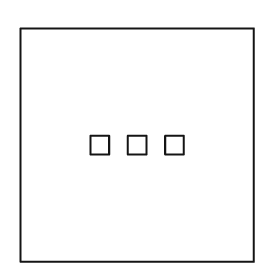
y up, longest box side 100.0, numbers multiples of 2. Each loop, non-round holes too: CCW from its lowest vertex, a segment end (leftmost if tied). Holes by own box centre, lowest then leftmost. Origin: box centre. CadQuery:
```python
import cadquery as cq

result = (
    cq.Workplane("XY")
    .moveTo(-50.0, -50.0)
    .lineTo(50.0, -50.0)
    .lineTo(50.0, 50.0)
    .lineTo(-50.0, 50.0)
    .close()
    .moveTo(-20.0, -4.0)
    .lineTo(-12.0, -4.0)
    .lineTo(-12.0, 4.0)
    .lineTo(-20.0, 4.0)
    .close()
    .moveTo(-4.0, -4.0)
    .lineTo(4.0, -4.0)
    .lineTo(4.0, 4.0)
    .lineTo(-4.0, 4.0)
    .close()
    .moveTo(12.0, -4.0)
    .lineTo(20.0, -4.0)
    .lineTo(20.0, 4.0)
    .lineTo(12.0, 4.0)
    .close()
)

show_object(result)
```